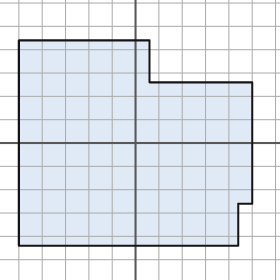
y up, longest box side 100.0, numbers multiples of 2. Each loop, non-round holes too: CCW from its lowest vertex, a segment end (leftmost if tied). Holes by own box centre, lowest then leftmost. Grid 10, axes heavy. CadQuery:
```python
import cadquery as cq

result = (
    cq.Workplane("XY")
    .moveTo(-50.0, -44.0)
    .lineTo(44.0, -44.0)
    .lineTo(44.0, -26.0)
    .lineTo(50.0, -26.0)
    .lineTo(50.0, 26.0)
    .lineTo(6.0, 26.0)
    .lineTo(6.0, 44.0)
    .lineTo(-50.0, 44.0)
    .close()
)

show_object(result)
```